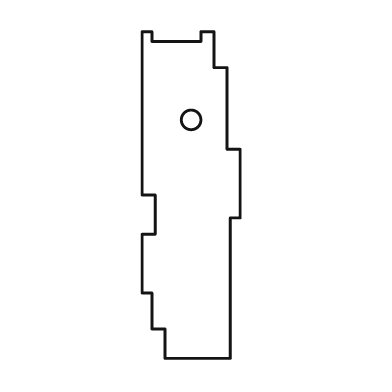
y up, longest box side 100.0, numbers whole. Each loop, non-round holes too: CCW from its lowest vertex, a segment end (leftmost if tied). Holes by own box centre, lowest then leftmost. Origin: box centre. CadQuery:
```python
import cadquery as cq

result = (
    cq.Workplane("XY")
    .moveTo(-8.0, -50.0)
    .lineTo(12.0, -50.0)
    .lineTo(12.0, -7.0)
    .lineTo(15.0, -7.0)
    .lineTo(15.0, 14.0)
    .lineTo(11.0, 14.0)
    .lineTo(11.0, 39.0)
    .lineTo(7.0, 39.0)
    .lineTo(7.0, 50.0)
    .lineTo(3.0, 50.0)
    .lineTo(3.0, 47.0)
    .lineTo(-12.0, 47.0)
    .lineTo(-12.0, 50.0)
    .lineTo(-15.0, 50.0)
    .lineTo(-15.0, 0.0)
    .lineTo(-11.0, 0.0)
    .lineTo(-11.0, -12.0)
    .lineTo(-15.0, -12.0)
    .lineTo(-15.0, -30.0)
    .lineTo(-12.0, -30.0)
    .lineTo(-12.0, -41.0)
    .lineTo(-8.0, -41.0)
    .close()
    .moveTo(0.0, 23.0)
    .circle(3.0)
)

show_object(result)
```